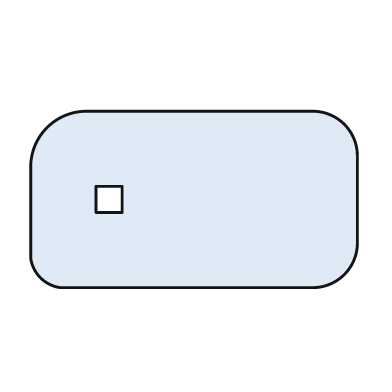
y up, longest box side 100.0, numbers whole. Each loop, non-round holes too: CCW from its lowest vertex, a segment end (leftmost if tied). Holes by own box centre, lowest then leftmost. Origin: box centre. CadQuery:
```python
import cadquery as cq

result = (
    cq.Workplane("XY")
    .moveTo(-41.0, -27.0)
    .lineTo(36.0, -27.0)
    .threePointArc((46.0, -23.0), (50.0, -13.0))
    .lineTo(50.0, 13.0)
    .threePointArc((46.0, 23.0), (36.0, 27.0))
    .lineTo(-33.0, 27.0)
    .threePointArc((-45.0, 22.0), (-50.0, 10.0))
    .lineTo(-50.0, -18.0)
    .threePointArc((-47.0, -24.0), (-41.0, -27.0))
    .close()
    .moveTo(-30.0, -4.0)
    .lineTo(-22.0, -4.0)
    .lineTo(-22.0, 4.0)
    .lineTo(-30.0, 4.0)
    .close()
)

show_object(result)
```